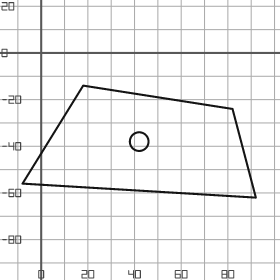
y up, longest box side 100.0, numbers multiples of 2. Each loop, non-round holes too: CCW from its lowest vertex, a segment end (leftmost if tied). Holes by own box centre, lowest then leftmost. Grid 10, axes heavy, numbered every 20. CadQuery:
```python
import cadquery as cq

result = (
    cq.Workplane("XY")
    .moveTo(92.0, -62.0)
    .lineTo(82.0, -24.0)
    .lineTo(18.0, -14.0)
    .lineTo(-8.0, -56.0)
    .close()
    .moveTo(42.0, -38.0)
    .circle(4.0)
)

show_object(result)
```